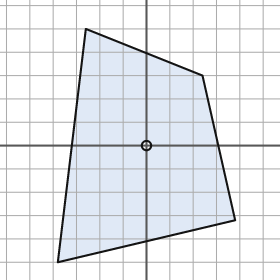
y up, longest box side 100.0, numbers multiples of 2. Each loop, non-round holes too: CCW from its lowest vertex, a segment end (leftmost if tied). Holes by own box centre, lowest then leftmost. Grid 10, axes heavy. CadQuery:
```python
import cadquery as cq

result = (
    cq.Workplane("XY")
    .moveTo(-38.0, -50.0)
    .lineTo(38.0, -32.0)
    .lineTo(24.0, 30.0)
    .lineTo(-26.0, 50.0)
    .close()
    .moveTo(0.0, 0.0)
    .circle(2.0)
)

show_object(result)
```